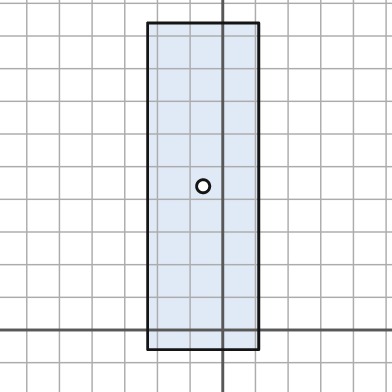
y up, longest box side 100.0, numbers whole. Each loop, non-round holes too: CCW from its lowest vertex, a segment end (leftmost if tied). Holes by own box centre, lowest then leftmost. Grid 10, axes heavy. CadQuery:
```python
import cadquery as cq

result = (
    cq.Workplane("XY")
    .moveTo(-23.0, -6.0)
    .lineTo(11.0, -6.0)
    .lineTo(11.0, 94.0)
    .lineTo(-23.0, 94.0)
    .close()
    .moveTo(-6.0, 44.0)
    .circle(2.0)
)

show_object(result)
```